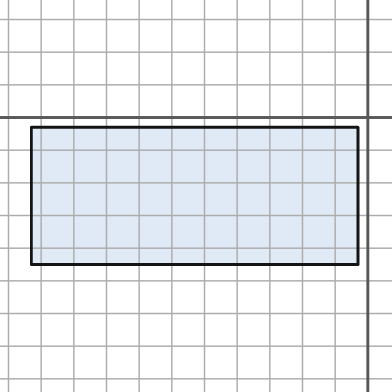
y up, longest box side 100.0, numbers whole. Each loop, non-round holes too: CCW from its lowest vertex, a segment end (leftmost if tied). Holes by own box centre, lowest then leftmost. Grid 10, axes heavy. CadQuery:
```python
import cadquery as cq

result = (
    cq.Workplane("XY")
    .moveTo(-103.0, -45.0)
    .lineTo(-3.0, -45.0)
    .lineTo(-3.0, -3.0)
    .lineTo(-103.0, -3.0)
    .close()
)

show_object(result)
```